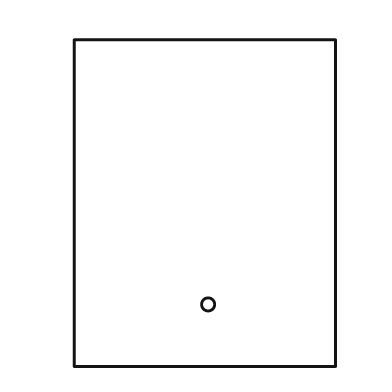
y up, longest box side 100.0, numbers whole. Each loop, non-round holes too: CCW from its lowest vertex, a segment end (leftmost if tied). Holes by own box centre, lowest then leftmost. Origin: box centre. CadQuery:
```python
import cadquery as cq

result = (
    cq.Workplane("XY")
    .moveTo(-40.0, -50.0)
    .lineTo(40.0, -50.0)
    .lineTo(40.0, 50.0)
    .lineTo(-40.0, 50.0)
    .close()
    .moveTo(1.0, -31.0)
    .circle(2.0)
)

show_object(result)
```